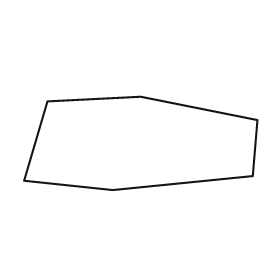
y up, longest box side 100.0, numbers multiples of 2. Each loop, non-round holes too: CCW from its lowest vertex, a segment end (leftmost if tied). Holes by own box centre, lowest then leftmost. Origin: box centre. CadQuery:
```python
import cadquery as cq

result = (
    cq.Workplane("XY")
    .moveTo(-12.0, -20.0)
    .lineTo(48.0, -14.0)
    .lineTo(50.0, 10.0)
    .lineTo(0.0, 20.0)
    .lineTo(-40.0, 18.0)
    .lineTo(-50.0, -16.0)
    .close()
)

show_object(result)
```